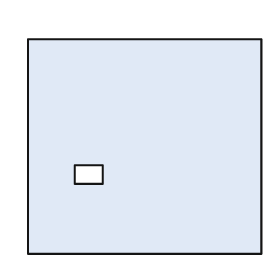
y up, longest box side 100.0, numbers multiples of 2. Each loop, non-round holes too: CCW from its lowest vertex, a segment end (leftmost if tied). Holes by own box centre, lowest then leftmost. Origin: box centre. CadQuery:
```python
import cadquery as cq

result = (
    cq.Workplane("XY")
    .moveTo(-50.0, -46.0)
    .lineTo(50.0, -46.0)
    .lineTo(50.0, 46.0)
    .lineTo(-50.0, 46.0)
    .close()
    .moveTo(-30.0, -16.0)
    .lineTo(-18.0, -16.0)
    .lineTo(-18.0, -8.0)
    .lineTo(-30.0, -8.0)
    .close()
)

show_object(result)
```